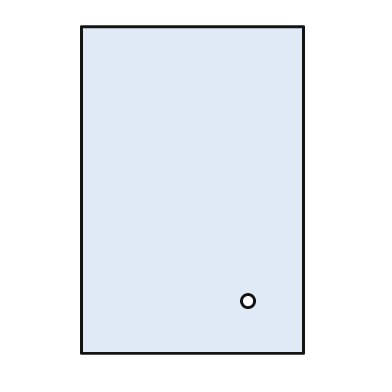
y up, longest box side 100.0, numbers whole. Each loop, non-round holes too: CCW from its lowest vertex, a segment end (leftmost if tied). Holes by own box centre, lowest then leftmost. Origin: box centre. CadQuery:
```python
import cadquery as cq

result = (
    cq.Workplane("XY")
    .moveTo(-34.0, -50.0)
    .lineTo(34.0, -50.0)
    .lineTo(34.0, 50.0)
    .lineTo(-34.0, 50.0)
    .close()
    .moveTo(17.0, -34.0)
    .circle(2.0)
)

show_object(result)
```